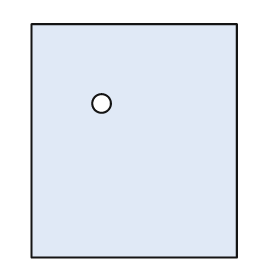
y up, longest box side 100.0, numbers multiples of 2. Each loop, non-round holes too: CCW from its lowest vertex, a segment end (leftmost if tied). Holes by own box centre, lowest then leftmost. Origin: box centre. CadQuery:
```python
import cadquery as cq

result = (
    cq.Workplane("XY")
    .moveTo(-44.0, -50.0)
    .lineTo(44.0, -50.0)
    .lineTo(44.0, 50.0)
    .lineTo(-44.0, 50.0)
    .close()
    .moveTo(-14.0, 16.0)
    .circle(4.0)
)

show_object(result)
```